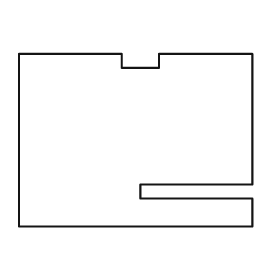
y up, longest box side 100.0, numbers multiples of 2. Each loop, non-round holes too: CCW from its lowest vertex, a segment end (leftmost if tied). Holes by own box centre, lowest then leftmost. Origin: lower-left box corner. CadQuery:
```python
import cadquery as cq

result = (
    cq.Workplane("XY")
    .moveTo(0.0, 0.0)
    .lineTo(100.0, 0.0)
    .lineTo(100.0, 12.0)
    .lineTo(52.0, 12.0)
    .lineTo(52.0, 18.0)
    .lineTo(100.0, 18.0)
    .lineTo(100.0, 74.0)
    .lineTo(60.0, 74.0)
    .lineTo(60.0, 68.0)
    .lineTo(44.0, 68.0)
    .lineTo(44.0, 74.0)
    .lineTo(0.0, 74.0)
    .close()
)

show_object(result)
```